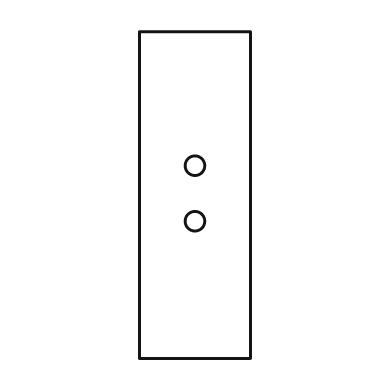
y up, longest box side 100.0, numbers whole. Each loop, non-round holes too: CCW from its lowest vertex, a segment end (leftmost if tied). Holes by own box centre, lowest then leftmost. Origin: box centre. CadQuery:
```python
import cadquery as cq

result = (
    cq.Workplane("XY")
    .moveTo(-17.0, -50.0)
    .lineTo(17.0, -50.0)
    .lineTo(17.0, 50.0)
    .lineTo(-17.0, 50.0)
    .close()
    .moveTo(0.0, -8.0)
    .circle(3.0)
    .moveTo(0.0, 9.0)
    .circle(3.0)
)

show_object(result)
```